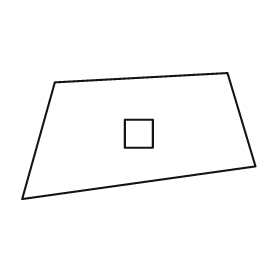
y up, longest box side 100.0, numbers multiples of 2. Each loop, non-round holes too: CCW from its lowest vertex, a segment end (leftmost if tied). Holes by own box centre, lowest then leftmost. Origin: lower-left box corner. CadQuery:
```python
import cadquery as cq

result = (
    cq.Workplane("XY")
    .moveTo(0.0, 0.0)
    .lineTo(100.0, 14.0)
    .lineTo(88.0, 54.0)
    .lineTo(14.0, 50.0)
    .close()
    .moveTo(44.0, 22.0)
    .lineTo(56.0, 22.0)
    .lineTo(56.0, 34.0)
    .lineTo(44.0, 34.0)
    .close()
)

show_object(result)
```